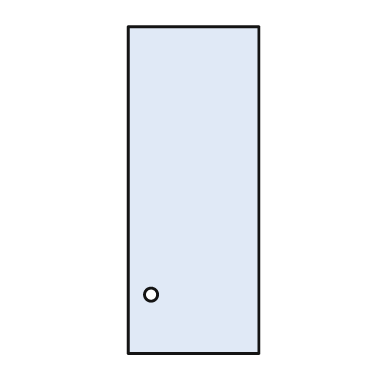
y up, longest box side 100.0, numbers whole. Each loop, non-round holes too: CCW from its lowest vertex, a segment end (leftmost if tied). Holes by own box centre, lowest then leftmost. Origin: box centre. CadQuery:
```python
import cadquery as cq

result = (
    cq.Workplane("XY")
    .moveTo(-20.0, -50.0)
    .lineTo(20.0, -50.0)
    .lineTo(20.0, 50.0)
    .lineTo(-20.0, 50.0)
    .close()
    .moveTo(-13.0, -32.0)
    .circle(2.0)
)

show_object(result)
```